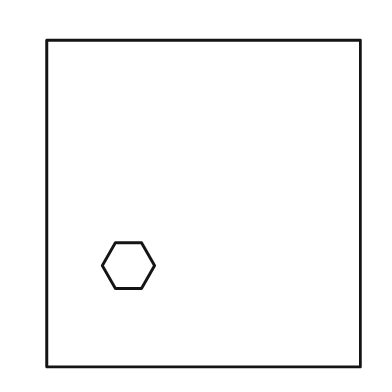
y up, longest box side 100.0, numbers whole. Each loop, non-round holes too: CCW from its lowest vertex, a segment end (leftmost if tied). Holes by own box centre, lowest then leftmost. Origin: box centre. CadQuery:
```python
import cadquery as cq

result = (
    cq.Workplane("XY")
    .moveTo(-48.0, -50.0)
    .lineTo(48.0, -50.0)
    .lineTo(48.0, 50.0)
    .lineTo(-48.0, 50.0)
    .close()
    .moveTo(-27.0, -26.0)
    .lineTo(-19.0, -26.0)
    .lineTo(-15.0, -19.0)
    .lineTo(-19.0, -12.0)
    .lineTo(-27.0, -12.0)
    .lineTo(-31.0, -19.0)
    .close()
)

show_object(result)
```